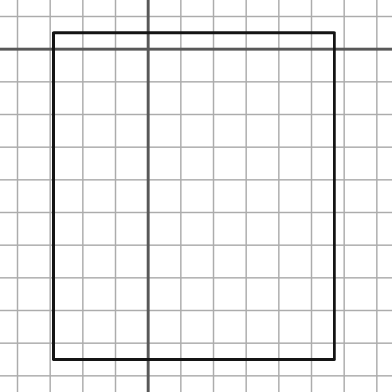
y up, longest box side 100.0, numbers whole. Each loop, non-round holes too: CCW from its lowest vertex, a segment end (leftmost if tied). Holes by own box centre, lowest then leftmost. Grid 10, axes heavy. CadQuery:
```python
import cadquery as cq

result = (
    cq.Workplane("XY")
    .moveTo(-29.0, -95.0)
    .lineTo(57.0, -95.0)
    .lineTo(57.0, 5.0)
    .lineTo(-29.0, 5.0)
    .close()
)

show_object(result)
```